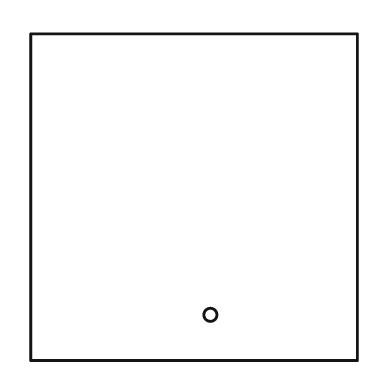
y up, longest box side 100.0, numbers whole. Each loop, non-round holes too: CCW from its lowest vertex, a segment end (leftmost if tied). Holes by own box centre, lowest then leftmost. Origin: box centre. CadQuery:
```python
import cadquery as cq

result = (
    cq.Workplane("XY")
    .moveTo(-50.0, -50.0)
    .lineTo(50.0, -50.0)
    .lineTo(50.0, 50.0)
    .lineTo(-50.0, 50.0)
    .close()
    .moveTo(5.0, -36.0)
    .circle(2.0)
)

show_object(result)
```